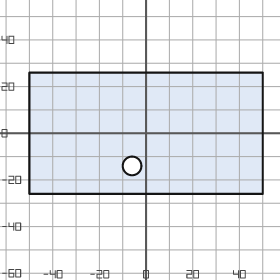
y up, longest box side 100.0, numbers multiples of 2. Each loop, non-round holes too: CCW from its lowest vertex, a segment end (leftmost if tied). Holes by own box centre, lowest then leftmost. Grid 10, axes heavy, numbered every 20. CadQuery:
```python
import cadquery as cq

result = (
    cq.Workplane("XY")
    .moveTo(-50.0, -26.0)
    .lineTo(50.0, -26.0)
    .lineTo(50.0, 26.0)
    .lineTo(-50.0, 26.0)
    .close()
    .moveTo(-6.0, -14.0)
    .circle(4.0)
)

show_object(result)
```